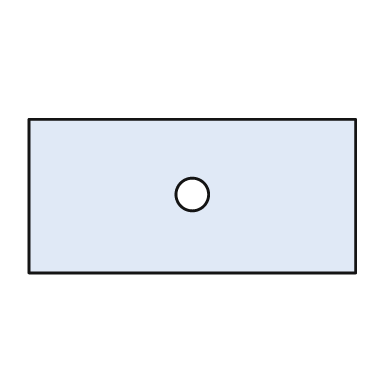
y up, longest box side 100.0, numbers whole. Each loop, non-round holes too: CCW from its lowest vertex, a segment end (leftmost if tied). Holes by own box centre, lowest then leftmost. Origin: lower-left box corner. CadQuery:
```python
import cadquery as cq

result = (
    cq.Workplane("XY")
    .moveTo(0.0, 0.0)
    .lineTo(100.0, 0.0)
    .lineTo(100.0, 47.0)
    .lineTo(0.0, 47.0)
    .close()
    .moveTo(50.0, 24.0)
    .circle(5.0)
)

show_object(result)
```